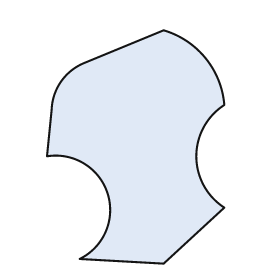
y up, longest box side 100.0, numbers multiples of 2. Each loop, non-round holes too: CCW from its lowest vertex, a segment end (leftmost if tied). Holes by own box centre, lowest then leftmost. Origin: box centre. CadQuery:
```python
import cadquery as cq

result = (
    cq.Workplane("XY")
    .moveTo(12.0, -50.0)
    .lineTo(38.0, -26.0)
    .threePointArc((26.0, -4.0), (38.0, 18.0))
    .threePointArc((30.0, 38.0), (12.0, 50.0))
    .lineTo(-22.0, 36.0)
    .threePointArc((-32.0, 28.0), (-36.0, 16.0))
    .lineTo(-38.0, -4.0)
    .threePointArc((-12.0, -20.0), (-24.0, -48.0))
    .close()
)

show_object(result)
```